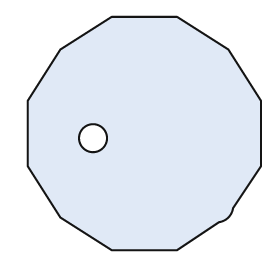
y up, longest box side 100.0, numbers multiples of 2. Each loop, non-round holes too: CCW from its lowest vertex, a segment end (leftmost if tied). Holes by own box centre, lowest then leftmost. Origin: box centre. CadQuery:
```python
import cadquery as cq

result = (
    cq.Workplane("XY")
    .moveTo(-14.0, -50.0)
    .lineTo(14.0, -50.0)
    .lineTo(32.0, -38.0)
    .threePointArc((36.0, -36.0), (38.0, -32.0))
    .lineTo(50.0, -14.0)
    .lineTo(50.0, 14.0)
    .lineTo(36.0, 36.0)
    .lineTo(14.0, 50.0)
    .lineTo(-14.0, 50.0)
    .lineTo(-36.0, 36.0)
    .lineTo(-50.0, 14.0)
    .lineTo(-50.0, -14.0)
    .lineTo(-36.0, -36.0)
    .close()
    .moveTo(-22.0, -2.0)
    .circle(6.0)
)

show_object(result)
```